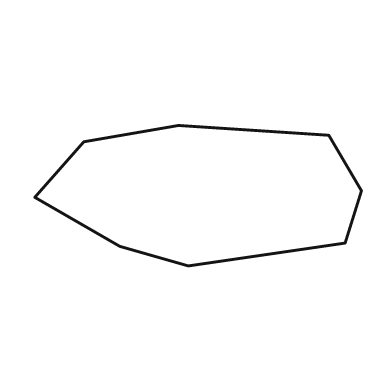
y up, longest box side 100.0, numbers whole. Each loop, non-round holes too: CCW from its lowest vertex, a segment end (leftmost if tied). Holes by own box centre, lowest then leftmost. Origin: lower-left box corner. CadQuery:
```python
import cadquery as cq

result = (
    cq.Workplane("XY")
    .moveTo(47.0, 0.0)
    .lineTo(95.0, 7.0)
    .lineTo(100.0, 23.0)
    .lineTo(90.0, 40.0)
    .lineTo(44.0, 43.0)
    .lineTo(15.0, 38.0)
    .lineTo(0.0, 21.0)
    .lineTo(26.0, 6.0)
    .close()
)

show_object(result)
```